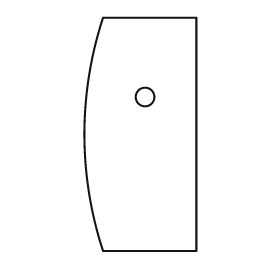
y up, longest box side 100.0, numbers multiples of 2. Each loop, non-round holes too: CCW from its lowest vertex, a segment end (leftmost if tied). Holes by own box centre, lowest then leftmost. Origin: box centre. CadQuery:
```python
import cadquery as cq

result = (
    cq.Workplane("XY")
    .moveTo(-16.0, -50.0)
    .lineTo(24.0, -50.0)
    .lineTo(24.0, 50.0)
    .lineTo(-16.0, 50.0)
    .threePointArc((-24.0, 0.0), (-16.0, -50.0))
    .close()
    .moveTo(2.0, 16.0)
    .circle(4.0)
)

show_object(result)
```